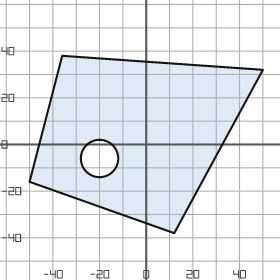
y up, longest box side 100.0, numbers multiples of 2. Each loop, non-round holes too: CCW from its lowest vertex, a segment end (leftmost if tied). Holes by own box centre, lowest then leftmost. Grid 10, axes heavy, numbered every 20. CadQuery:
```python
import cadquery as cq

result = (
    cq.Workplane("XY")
    .moveTo(12.0, -38.0)
    .lineTo(50.0, 32.0)
    .lineTo(-36.0, 38.0)
    .lineTo(-50.0, -16.0)
    .close()
    .moveTo(-20.0, -6.0)
    .circle(8.0)
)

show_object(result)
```